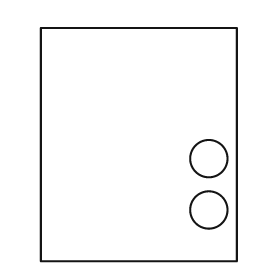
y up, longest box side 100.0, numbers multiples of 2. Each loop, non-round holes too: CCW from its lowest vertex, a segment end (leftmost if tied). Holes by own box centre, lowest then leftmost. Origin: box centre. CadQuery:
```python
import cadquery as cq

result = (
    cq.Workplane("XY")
    .moveTo(-42.0, -50.0)
    .lineTo(42.0, -50.0)
    .lineTo(42.0, 50.0)
    .lineTo(-42.0, 50.0)
    .close()
    .moveTo(30.0, -28.0)
    .circle(8.0)
    .moveTo(30.0, -6.0)
    .circle(8.0)
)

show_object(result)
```